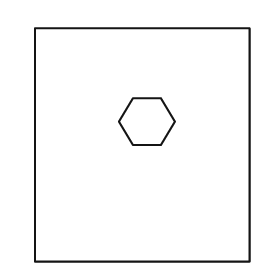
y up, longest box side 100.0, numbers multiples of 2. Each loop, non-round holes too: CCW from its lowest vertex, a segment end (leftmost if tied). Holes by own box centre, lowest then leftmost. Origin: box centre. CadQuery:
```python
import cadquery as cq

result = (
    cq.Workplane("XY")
    .moveTo(-46.0, -50.0)
    .lineTo(46.0, -50.0)
    .lineTo(46.0, 50.0)
    .lineTo(-46.0, 50.0)
    .close()
    .moveTo(-4.0, 0.0)
    .lineTo(8.0, 0.0)
    .lineTo(14.0, 10.0)
    .lineTo(8.0, 20.0)
    .lineTo(-4.0, 20.0)
    .lineTo(-10.0, 10.0)
    .close()
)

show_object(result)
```